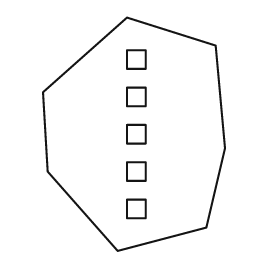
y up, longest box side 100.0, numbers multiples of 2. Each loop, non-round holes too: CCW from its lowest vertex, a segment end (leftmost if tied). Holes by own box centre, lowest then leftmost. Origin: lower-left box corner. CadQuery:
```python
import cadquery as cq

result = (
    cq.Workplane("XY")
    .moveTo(32.0, 0.0)
    .lineTo(70.0, 10.0)
    .lineTo(78.0, 44.0)
    .lineTo(74.0, 88.0)
    .lineTo(36.0, 100.0)
    .lineTo(0.0, 68.0)
    .lineTo(2.0, 34.0)
    .close()
    .moveTo(36.0, 14.0)
    .lineTo(44.0, 14.0)
    .lineTo(44.0, 22.0)
    .lineTo(36.0, 22.0)
    .close()
    .moveTo(36.0, 30.0)
    .lineTo(44.0, 30.0)
    .lineTo(44.0, 38.0)
    .lineTo(36.0, 38.0)
    .close()
    .moveTo(36.0, 46.0)
    .lineTo(44.0, 46.0)
    .lineTo(44.0, 54.0)
    .lineTo(36.0, 54.0)
    .close()
    .moveTo(36.0, 62.0)
    .lineTo(44.0, 62.0)
    .lineTo(44.0, 70.0)
    .lineTo(36.0, 70.0)
    .close()
    .moveTo(36.0, 78.0)
    .lineTo(44.0, 78.0)
    .lineTo(44.0, 86.0)
    .lineTo(36.0, 86.0)
    .close()
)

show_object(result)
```